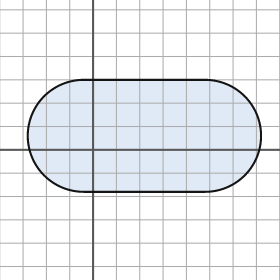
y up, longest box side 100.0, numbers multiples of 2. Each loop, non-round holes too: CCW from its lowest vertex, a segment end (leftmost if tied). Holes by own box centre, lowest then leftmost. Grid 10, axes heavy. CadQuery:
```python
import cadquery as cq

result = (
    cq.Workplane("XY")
    .moveTo(-4.0, -18.0)
    .lineTo(48.0, -18.0)
    .threePointArc((72.0, 6.0), (48.0, 30.0))
    .lineTo(-4.0, 30.0)
    .threePointArc((-28.0, 6.0), (-4.0, -18.0))
    .close()
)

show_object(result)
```